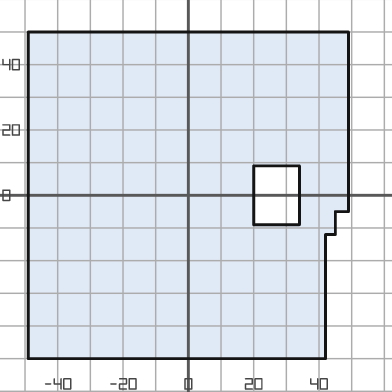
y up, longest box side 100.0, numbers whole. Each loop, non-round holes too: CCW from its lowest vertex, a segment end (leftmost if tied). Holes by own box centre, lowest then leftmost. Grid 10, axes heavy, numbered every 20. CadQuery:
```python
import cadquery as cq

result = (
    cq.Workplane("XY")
    .moveTo(-49.0, -50.0)
    .lineTo(42.0, -50.0)
    .lineTo(42.0, -12.0)
    .lineTo(45.0, -12.0)
    .lineTo(45.0, -5.0)
    .lineTo(49.0, -5.0)
    .lineTo(49.0, 50.0)
    .lineTo(-49.0, 50.0)
    .close()
    .moveTo(20.0, -9.0)
    .lineTo(34.0, -9.0)
    .lineTo(34.0, 9.0)
    .lineTo(20.0, 9.0)
    .close()
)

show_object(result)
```